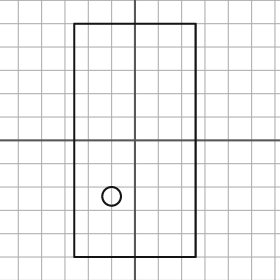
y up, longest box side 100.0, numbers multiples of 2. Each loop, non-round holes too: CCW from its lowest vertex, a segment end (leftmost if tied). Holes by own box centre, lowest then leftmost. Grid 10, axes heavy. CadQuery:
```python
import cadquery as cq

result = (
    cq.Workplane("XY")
    .moveTo(-26.0, -50.0)
    .lineTo(26.0, -50.0)
    .lineTo(26.0, 50.0)
    .lineTo(-26.0, 50.0)
    .close()
    .moveTo(-10.0, -24.0)
    .circle(4.0)
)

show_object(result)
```